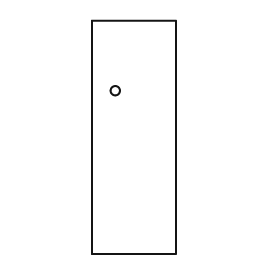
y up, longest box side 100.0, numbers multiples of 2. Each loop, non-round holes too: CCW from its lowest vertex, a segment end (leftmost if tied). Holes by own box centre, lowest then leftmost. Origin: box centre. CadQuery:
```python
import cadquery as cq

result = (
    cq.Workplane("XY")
    .moveTo(-18.0, -50.0)
    .lineTo(18.0, -50.0)
    .lineTo(18.0, 50.0)
    .lineTo(-18.0, 50.0)
    .close()
    .moveTo(-8.0, 20.0)
    .circle(2.0)
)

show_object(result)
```